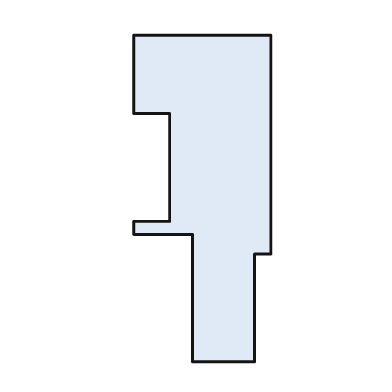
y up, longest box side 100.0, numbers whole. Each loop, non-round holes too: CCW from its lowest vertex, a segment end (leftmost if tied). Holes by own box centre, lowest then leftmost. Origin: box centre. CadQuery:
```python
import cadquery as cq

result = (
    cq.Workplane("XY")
    .moveTo(-3.0, -50.0)
    .lineTo(16.0, -50.0)
    .lineTo(16.0, -17.0)
    .lineTo(21.0, -17.0)
    .lineTo(21.0, 50.0)
    .lineTo(-21.0, 50.0)
    .lineTo(-21.0, 26.0)
    .lineTo(-10.0, 26.0)
    .lineTo(-10.0, -7.0)
    .lineTo(-21.0, -7.0)
    .lineTo(-21.0, -11.0)
    .lineTo(-3.0, -11.0)
    .close()
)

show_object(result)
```